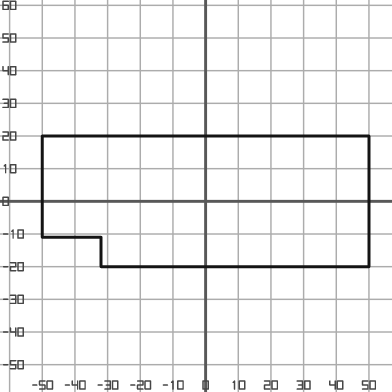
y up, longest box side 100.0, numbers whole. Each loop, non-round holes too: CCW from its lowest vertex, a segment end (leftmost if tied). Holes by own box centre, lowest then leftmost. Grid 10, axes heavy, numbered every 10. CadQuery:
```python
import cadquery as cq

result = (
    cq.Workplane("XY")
    .moveTo(-32.0, -20.0)
    .lineTo(50.0, -20.0)
    .lineTo(50.0, 20.0)
    .lineTo(-50.0, 20.0)
    .lineTo(-50.0, -11.0)
    .lineTo(-32.0, -11.0)
    .close()
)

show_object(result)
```